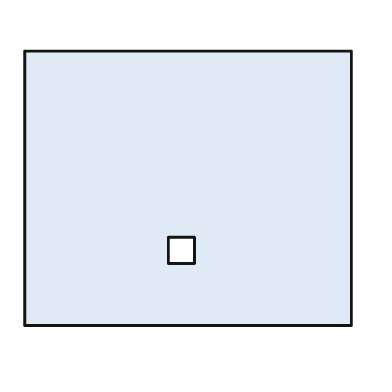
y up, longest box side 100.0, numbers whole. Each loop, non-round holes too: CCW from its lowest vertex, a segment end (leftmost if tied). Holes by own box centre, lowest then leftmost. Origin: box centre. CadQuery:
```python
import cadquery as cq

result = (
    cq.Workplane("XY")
    .moveTo(-50.0, -42.0)
    .lineTo(50.0, -42.0)
    .lineTo(50.0, 42.0)
    .lineTo(-50.0, 42.0)
    .close()
    .moveTo(-6.0, -23.0)
    .lineTo(2.0, -23.0)
    .lineTo(2.0, -15.0)
    .lineTo(-6.0, -15.0)
    .close()
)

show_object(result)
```